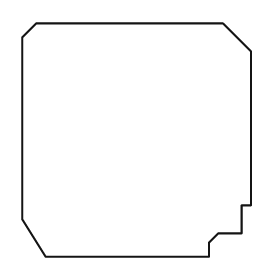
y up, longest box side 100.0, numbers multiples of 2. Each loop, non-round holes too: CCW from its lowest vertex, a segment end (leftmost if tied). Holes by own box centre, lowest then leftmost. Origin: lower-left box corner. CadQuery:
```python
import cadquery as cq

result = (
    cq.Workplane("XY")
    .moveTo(10.0, 0.0)
    .lineTo(80.0, 0.0)
    .lineTo(80.0, 6.0)
    .lineTo(84.0, 10.0)
    .lineTo(94.0, 10.0)
    .lineTo(94.0, 22.0)
    .lineTo(98.0, 22.0)
    .lineTo(98.0, 88.0)
    .lineTo(86.0, 100.0)
    .lineTo(6.0, 100.0)
    .lineTo(0.0, 94.0)
    .lineTo(0.0, 16.0)
    .close()
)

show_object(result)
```